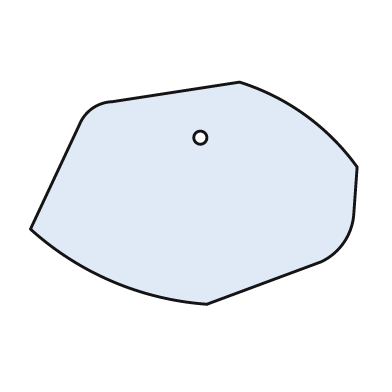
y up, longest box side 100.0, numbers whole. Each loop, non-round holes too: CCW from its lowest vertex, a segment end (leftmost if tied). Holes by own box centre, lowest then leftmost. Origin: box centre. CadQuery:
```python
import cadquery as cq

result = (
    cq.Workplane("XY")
    .moveTo(4.0, -34.0)
    .lineTo(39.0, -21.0)
    .threePointArc((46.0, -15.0), (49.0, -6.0))
    .lineTo(50.0, 8.0)
    .threePointArc((34.0, 24.0), (14.0, 34.0))
    .lineTo(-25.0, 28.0)
    .threePointArc((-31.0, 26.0), (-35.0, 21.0))
    .lineTo(-50.0, -11.0)
    .threePointArc((-25.0, -27.0), (4.0, -34.0))
    .close()
    .moveTo(2.0, 17.0)
    .circle(2.0)
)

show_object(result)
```